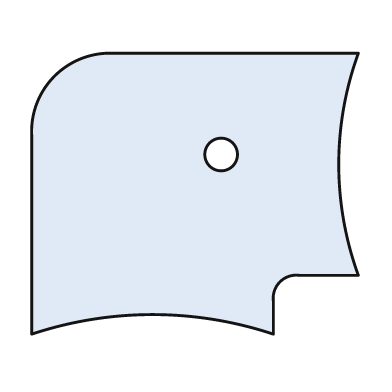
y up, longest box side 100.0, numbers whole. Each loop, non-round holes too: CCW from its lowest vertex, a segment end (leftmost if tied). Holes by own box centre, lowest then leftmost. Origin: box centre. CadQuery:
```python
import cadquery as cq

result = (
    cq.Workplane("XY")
    .moveTo(-50.0, -43.0)
    .threePointArc((-13.0, -37.0), (24.0, -43.0))
    .lineTo(24.0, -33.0)
    .threePointArc((26.0, -27.0), (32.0, -25.0))
    .lineTo(50.0, -25.0)
    .threePointArc((44.0, 9.0), (50.0, 43.0))
    .lineTo(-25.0, 43.0)
    .threePointArc((-43.0, 36.0), (-50.0, 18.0))
    .close()
    .moveTo(8.0, 12.0)
    .circle(5.0)
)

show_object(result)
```